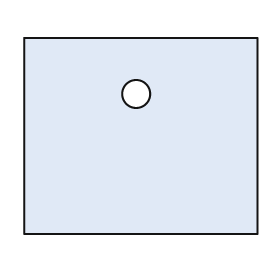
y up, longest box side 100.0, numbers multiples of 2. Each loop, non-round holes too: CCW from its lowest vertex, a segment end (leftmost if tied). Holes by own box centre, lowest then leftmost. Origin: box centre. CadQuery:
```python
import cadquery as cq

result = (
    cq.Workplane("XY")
    .moveTo(-50.0, -42.0)
    .lineTo(50.0, -42.0)
    .lineTo(50.0, 42.0)
    .lineTo(-50.0, 42.0)
    .close()
    .moveTo(-2.0, 18.0)
    .circle(6.0)
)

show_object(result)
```